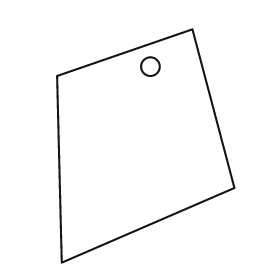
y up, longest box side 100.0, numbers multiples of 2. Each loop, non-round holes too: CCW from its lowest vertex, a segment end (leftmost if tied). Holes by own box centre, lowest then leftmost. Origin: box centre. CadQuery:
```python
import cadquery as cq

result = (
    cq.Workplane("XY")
    .moveTo(-36.0, -50.0)
    .lineTo(38.0, -18.0)
    .lineTo(20.0, 50.0)
    .lineTo(-38.0, 30.0)
    .close()
    .moveTo(2.0, 34.0)
    .circle(4.0)
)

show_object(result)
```